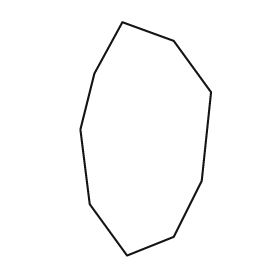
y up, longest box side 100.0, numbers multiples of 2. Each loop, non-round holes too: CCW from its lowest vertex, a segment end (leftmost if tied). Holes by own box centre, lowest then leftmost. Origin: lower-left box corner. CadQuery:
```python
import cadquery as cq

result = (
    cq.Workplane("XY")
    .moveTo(20.0, 0.0)
    .lineTo(40.0, 8.0)
    .lineTo(52.0, 32.0)
    .lineTo(56.0, 70.0)
    .lineTo(40.0, 92.0)
    .lineTo(18.0, 100.0)
    .lineTo(6.0, 78.0)
    .lineTo(0.0, 54.0)
    .lineTo(4.0, 22.0)
    .close()
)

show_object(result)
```